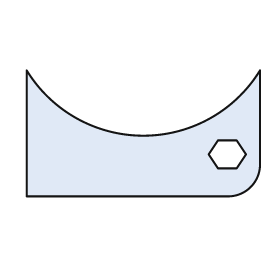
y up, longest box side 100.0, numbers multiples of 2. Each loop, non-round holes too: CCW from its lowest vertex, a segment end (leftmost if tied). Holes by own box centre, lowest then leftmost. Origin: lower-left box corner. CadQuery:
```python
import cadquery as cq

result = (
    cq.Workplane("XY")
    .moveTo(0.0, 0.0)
    .lineTo(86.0, 0.0)
    .threePointArc((96.0, 4.0), (100.0, 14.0))
    .lineTo(100.0, 54.0)
    .threePointArc((50.0, 26.0), (0.0, 54.0))
    .close()
    .moveTo(82.0, 12.0)
    .lineTo(90.0, 12.0)
    .lineTo(94.0, 18.0)
    .lineTo(90.0, 24.0)
    .lineTo(82.0, 24.0)
    .lineTo(78.0, 18.0)
    .close()
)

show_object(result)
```